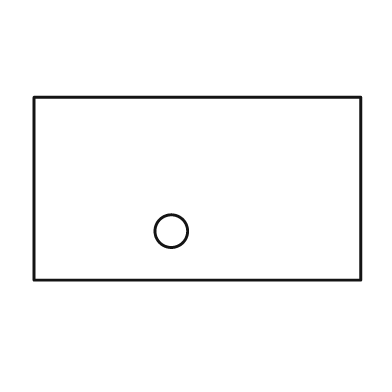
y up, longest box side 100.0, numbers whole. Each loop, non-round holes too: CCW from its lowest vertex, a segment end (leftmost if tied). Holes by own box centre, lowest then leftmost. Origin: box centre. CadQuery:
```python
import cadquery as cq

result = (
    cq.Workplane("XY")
    .moveTo(-50.0, -28.0)
    .lineTo(50.0, -28.0)
    .lineTo(50.0, 28.0)
    .lineTo(-50.0, 28.0)
    .close()
    .moveTo(-8.0, -13.0)
    .circle(5.0)
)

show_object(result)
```